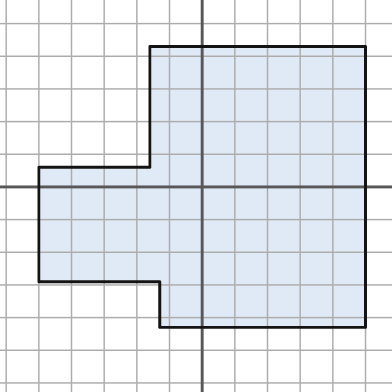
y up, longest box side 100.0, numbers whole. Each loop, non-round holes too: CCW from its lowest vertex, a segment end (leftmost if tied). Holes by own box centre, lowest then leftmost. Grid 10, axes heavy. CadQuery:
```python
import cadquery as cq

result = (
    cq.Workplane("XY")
    .moveTo(-13.0, -43.0)
    .lineTo(50.0, -43.0)
    .lineTo(50.0, 43.0)
    .lineTo(-16.0, 43.0)
    .lineTo(-16.0, 6.0)
    .lineTo(-50.0, 6.0)
    .lineTo(-50.0, -29.0)
    .lineTo(-13.0, -29.0)
    .close()
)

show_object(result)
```